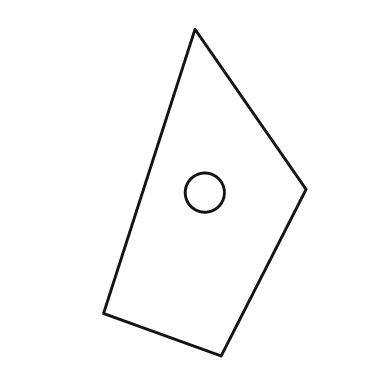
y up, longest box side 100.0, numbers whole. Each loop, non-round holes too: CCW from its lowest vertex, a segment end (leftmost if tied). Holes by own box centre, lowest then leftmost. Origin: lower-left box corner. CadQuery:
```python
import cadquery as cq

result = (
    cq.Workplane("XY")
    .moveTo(36.0, 0.0)
    .lineTo(62.0, 51.0)
    .lineTo(28.0, 100.0)
    .lineTo(0.0, 13.0)
    .close()
    .moveTo(31.0, 50.0)
    .circle(6.0)
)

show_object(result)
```